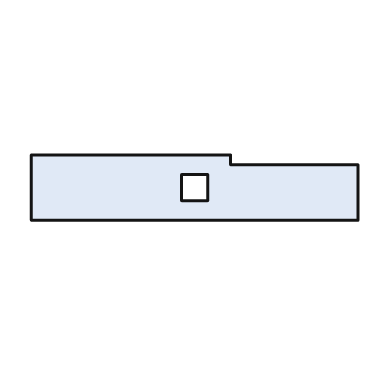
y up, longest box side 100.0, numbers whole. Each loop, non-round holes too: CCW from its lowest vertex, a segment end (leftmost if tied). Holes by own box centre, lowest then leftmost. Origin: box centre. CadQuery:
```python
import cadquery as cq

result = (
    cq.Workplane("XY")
    .moveTo(-50.0, -10.0)
    .lineTo(50.0, -10.0)
    .lineTo(50.0, 7.0)
    .lineTo(11.0, 7.0)
    .lineTo(11.0, 10.0)
    .lineTo(-50.0, 10.0)
    .close()
    .moveTo(-4.0, -4.0)
    .lineTo(4.0, -4.0)
    .lineTo(4.0, 4.0)
    .lineTo(-4.0, 4.0)
    .close()
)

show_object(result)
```